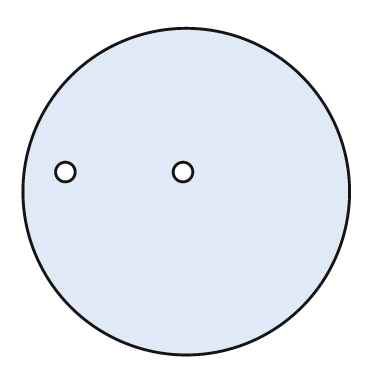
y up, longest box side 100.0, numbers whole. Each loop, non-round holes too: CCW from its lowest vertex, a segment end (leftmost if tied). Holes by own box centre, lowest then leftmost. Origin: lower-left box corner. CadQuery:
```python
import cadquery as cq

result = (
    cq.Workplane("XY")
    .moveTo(50.0, 50.0)
    .circle(50.0)
    .moveTo(13.0, 56.0)
    .circle(3.0)
    .moveTo(49.0, 56.0)
    .circle(3.0)
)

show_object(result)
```